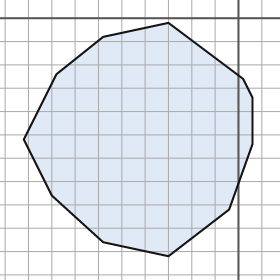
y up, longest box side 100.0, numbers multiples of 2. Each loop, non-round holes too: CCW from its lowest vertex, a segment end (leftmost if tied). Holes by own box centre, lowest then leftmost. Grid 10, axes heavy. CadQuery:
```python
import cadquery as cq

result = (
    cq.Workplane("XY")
    .moveTo(-30.0, -102.0)
    .lineTo(-4.0, -82.0)
    .lineTo(6.0, -54.0)
    .lineTo(6.0, -34.0)
    .lineTo(2.0, -26.0)
    .lineTo(-30.0, -2.0)
    .lineTo(-58.0, -8.0)
    .lineTo(-78.0, -24.0)
    .lineTo(-92.0, -52.0)
    .lineTo(-80.0, -76.0)
    .lineTo(-58.0, -96.0)
    .close()
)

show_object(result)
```